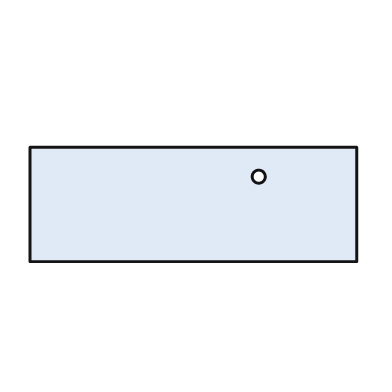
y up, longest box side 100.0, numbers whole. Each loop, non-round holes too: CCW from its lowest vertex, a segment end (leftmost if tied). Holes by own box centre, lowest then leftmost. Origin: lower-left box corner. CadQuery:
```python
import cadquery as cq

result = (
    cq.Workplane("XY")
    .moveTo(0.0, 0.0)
    .lineTo(100.0, 0.0)
    .lineTo(100.0, 35.0)
    .lineTo(0.0, 35.0)
    .close()
    .moveTo(70.0, 26.0)
    .circle(2.0)
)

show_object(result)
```